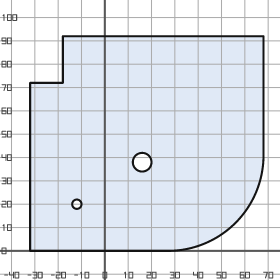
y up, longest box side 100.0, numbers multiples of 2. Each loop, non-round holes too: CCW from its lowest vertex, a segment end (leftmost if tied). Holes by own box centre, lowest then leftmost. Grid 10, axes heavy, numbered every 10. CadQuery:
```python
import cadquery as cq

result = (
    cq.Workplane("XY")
    .moveTo(-32.0, 0.0)
    .lineTo(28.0, 0.0)
    .threePointArc((56.0, 12.0), (68.0, 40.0))
    .lineTo(68.0, 92.0)
    .lineTo(-18.0, 92.0)
    .lineTo(-18.0, 72.0)
    .lineTo(-32.0, 72.0)
    .close()
    .moveTo(-12.0, 20.0)
    .circle(2.0)
    .moveTo(16.0, 38.0)
    .circle(4.0)
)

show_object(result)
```